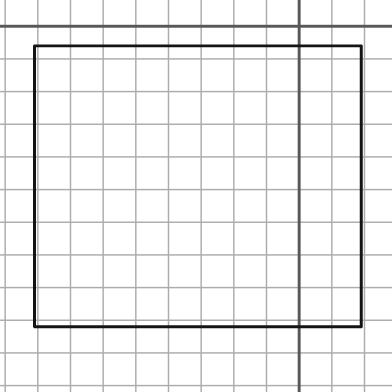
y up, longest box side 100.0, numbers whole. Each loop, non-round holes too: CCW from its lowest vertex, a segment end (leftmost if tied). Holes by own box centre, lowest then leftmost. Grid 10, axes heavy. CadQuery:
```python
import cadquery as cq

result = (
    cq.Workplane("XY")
    .moveTo(-81.0, -92.0)
    .lineTo(19.0, -92.0)
    .lineTo(19.0, -6.0)
    .lineTo(-81.0, -6.0)
    .close()
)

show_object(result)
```